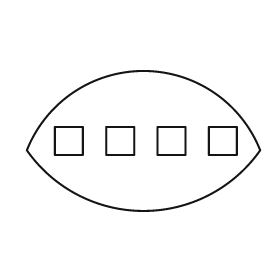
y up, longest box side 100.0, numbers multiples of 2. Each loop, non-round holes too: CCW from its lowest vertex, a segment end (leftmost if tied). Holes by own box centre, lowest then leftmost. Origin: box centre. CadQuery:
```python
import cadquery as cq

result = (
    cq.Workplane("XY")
    .moveTo(-50.0, -4.0)
    .threePointArc((0.0, -30.0), (50.0, -4.0))
    .threePointArc((0.0, 30.0), (-50.0, -4.0))
    .close()
    .moveTo(-38.0, -6.0)
    .lineTo(-26.0, -6.0)
    .lineTo(-26.0, 6.0)
    .lineTo(-38.0, 6.0)
    .close()
    .moveTo(-16.0, -6.0)
    .lineTo(-4.0, -6.0)
    .lineTo(-4.0, 6.0)
    .lineTo(-16.0, 6.0)
    .close()
    .moveTo(6.0, -6.0)
    .lineTo(18.0, -6.0)
    .lineTo(18.0, 6.0)
    .lineTo(6.0, 6.0)
    .close()
    .moveTo(28.0, -6.0)
    .lineTo(40.0, -6.0)
    .lineTo(40.0, 6.0)
    .lineTo(28.0, 6.0)
    .close()
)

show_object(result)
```